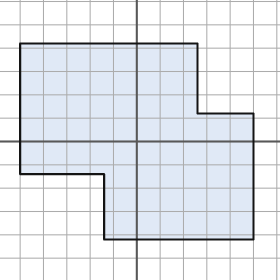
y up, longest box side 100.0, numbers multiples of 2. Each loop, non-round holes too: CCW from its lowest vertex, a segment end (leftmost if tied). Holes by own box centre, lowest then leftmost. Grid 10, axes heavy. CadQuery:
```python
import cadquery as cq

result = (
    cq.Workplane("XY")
    .moveTo(-14.0, -42.0)
    .lineTo(50.0, -42.0)
    .lineTo(50.0, 12.0)
    .lineTo(26.0, 12.0)
    .lineTo(26.0, 42.0)
    .lineTo(-50.0, 42.0)
    .lineTo(-50.0, -14.0)
    .lineTo(-14.0, -14.0)
    .close()
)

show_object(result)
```